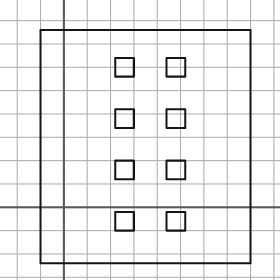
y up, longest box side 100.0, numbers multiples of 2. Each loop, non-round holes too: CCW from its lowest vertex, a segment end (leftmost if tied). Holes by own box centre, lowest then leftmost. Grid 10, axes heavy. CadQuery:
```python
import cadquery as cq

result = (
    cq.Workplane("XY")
    .moveTo(-10.0, -24.0)
    .lineTo(80.0, -24.0)
    .lineTo(80.0, 76.0)
    .lineTo(-10.0, 76.0)
    .close()
    .moveTo(22.0, -10.0)
    .lineTo(30.0, -10.0)
    .lineTo(30.0, -2.0)
    .lineTo(22.0, -2.0)
    .close()
    .moveTo(44.0, -10.0)
    .lineTo(52.0, -10.0)
    .lineTo(52.0, -2.0)
    .lineTo(44.0, -2.0)
    .close()
    .moveTo(22.0, 12.0)
    .lineTo(30.0, 12.0)
    .lineTo(30.0, 20.0)
    .lineTo(22.0, 20.0)
    .close()
    .moveTo(44.0, 12.0)
    .lineTo(52.0, 12.0)
    .lineTo(52.0, 20.0)
    .lineTo(44.0, 20.0)
    .close()
    .moveTo(22.0, 34.0)
    .lineTo(30.0, 34.0)
    .lineTo(30.0, 42.0)
    .lineTo(22.0, 42.0)
    .close()
    .moveTo(44.0, 34.0)
    .lineTo(52.0, 34.0)
    .lineTo(52.0, 42.0)
    .lineTo(44.0, 42.0)
    .close()
    .moveTo(22.0, 56.0)
    .lineTo(30.0, 56.0)
    .lineTo(30.0, 64.0)
    .lineTo(22.0, 64.0)
    .close()
    .moveTo(44.0, 56.0)
    .lineTo(52.0, 56.0)
    .lineTo(52.0, 64.0)
    .lineTo(44.0, 64.0)
    .close()
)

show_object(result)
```